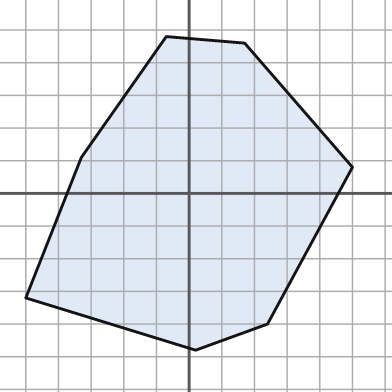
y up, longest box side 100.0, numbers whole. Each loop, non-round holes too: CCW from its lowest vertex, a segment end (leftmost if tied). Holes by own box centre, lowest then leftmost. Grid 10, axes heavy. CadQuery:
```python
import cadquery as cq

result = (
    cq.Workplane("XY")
    .moveTo(2.0, -48.0)
    .lineTo(24.0, -40.0)
    .lineTo(50.0, 8.0)
    .lineTo(17.0, 46.0)
    .lineTo(-7.0, 48.0)
    .lineTo(-33.0, 11.0)
    .lineTo(-50.0, -32.0)
    .close()
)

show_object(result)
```